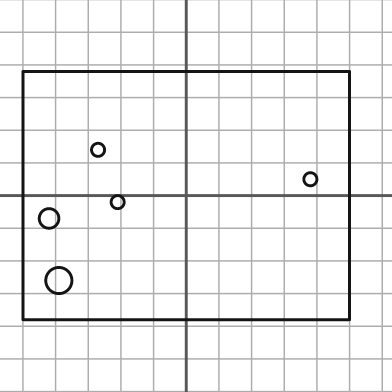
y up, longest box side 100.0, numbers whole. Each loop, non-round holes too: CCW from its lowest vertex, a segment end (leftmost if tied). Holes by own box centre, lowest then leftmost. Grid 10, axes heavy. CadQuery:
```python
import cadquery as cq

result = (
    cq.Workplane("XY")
    .moveTo(-50.0, -38.0)
    .lineTo(50.0, -38.0)
    .lineTo(50.0, 38.0)
    .lineTo(-50.0, 38.0)
    .close()
    .moveTo(-39.0, -26.0)
    .circle(4.0)
    .moveTo(-42.0, -7.0)
    .circle(3.0)
    .moveTo(-21.0, -2.0)
    .circle(2.0)
    .moveTo(38.0, 5.0)
    .circle(2.0)
    .moveTo(-27.0, 14.0)
    .circle(2.0)
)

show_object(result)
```